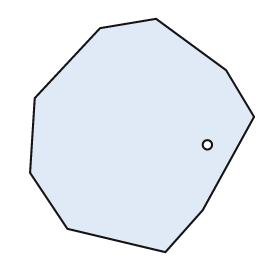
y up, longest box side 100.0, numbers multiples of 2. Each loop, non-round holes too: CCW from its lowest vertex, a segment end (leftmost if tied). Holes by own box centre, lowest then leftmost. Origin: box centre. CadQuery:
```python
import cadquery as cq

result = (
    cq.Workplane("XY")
    .moveTo(10.0, -50.0)
    .lineTo(26.0, -32.0)
    .lineTo(48.0, 8.0)
    .lineTo(36.0, 28.0)
    .lineTo(6.0, 50.0)
    .lineTo(-18.0, 46.0)
    .lineTo(-46.0, 16.0)
    .lineTo(-48.0, -16.0)
    .lineTo(-32.0, -40.0)
    .close()
    .moveTo(28.0, -4.0)
    .circle(2.0)
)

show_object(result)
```